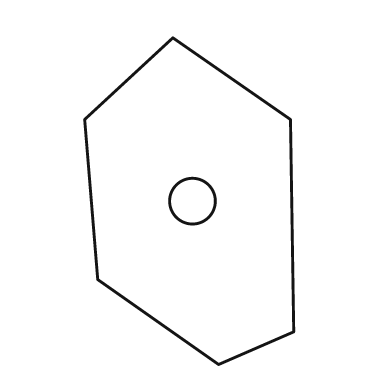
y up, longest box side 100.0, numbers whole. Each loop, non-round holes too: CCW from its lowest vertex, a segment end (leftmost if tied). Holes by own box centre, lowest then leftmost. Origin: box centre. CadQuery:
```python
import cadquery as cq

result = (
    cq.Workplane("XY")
    .moveTo(9.0, -50.0)
    .lineTo(32.0, -40.0)
    .lineTo(31.0, 25.0)
    .lineTo(-5.0, 50.0)
    .lineTo(-32.0, 25.0)
    .lineTo(-28.0, -24.0)
    .close()
    .moveTo(1.0, 0.0)
    .circle(7.0)
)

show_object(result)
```